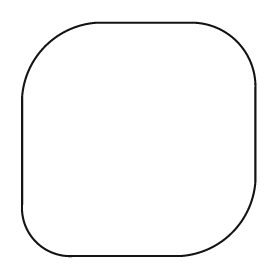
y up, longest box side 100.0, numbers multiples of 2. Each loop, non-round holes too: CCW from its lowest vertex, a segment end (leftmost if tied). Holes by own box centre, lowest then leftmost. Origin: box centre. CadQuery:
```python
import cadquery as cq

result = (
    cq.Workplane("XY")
    .moveTo(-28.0, -50.0)
    .lineTo(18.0, -50.0)
    .threePointArc((40.0, -40.0), (50.0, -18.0))
    .lineTo(50.0, 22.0)
    .threePointArc((42.0, 42.0), (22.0, 50.0))
    .lineTo(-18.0, 50.0)
    .threePointArc((-40.0, 40.0), (-50.0, 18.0))
    .lineTo(-50.0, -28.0)
    .threePointArc((-44.0, -44.0), (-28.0, -50.0))
    .close()
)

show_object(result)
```